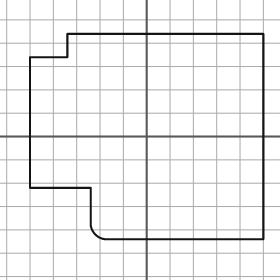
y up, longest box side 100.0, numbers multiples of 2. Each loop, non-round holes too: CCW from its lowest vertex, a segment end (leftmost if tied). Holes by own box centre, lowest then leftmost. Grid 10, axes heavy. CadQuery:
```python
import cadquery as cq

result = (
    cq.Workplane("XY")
    .moveTo(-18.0, -44.0)
    .lineTo(50.0, -44.0)
    .lineTo(50.0, 44.0)
    .lineTo(-34.0, 44.0)
    .lineTo(-34.0, 34.0)
    .lineTo(-50.0, 34.0)
    .lineTo(-50.0, -22.0)
    .lineTo(-24.0, -22.0)
    .lineTo(-24.0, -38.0)
    .threePointArc((-22.0, -42.0), (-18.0, -44.0))
    .close()
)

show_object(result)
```